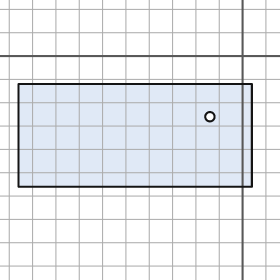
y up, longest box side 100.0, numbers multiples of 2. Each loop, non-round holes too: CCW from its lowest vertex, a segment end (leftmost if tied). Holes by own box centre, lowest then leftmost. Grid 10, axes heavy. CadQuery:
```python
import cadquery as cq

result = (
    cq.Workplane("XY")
    .moveTo(-96.0, -56.0)
    .lineTo(4.0, -56.0)
    .lineTo(4.0, -12.0)
    .lineTo(-96.0, -12.0)
    .close()
    .moveTo(-14.0, -26.0)
    .circle(2.0)
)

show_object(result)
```